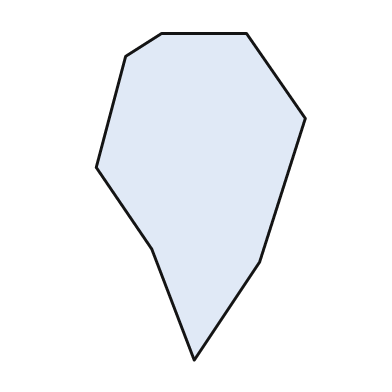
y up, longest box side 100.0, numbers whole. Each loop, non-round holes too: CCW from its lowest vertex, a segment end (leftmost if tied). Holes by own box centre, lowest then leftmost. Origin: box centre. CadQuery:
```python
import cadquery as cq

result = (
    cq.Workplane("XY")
    .moveTo(-2.0, -50.0)
    .lineTo(18.0, -20.0)
    .lineTo(32.0, 24.0)
    .lineTo(14.0, 50.0)
    .lineTo(-12.0, 50.0)
    .lineTo(-23.0, 43.0)
    .lineTo(-32.0, 9.0)
    .lineTo(-15.0, -16.0)
    .close()
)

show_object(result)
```